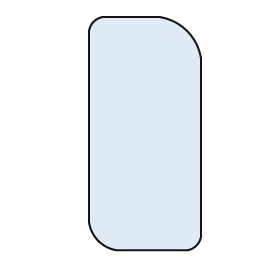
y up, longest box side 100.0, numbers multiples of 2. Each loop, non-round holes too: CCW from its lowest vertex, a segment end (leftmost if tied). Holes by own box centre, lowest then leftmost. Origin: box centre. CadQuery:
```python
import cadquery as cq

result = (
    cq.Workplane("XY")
    .moveTo(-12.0, -50.0)
    .lineTo(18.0, -50.0)
    .threePointArc((22.0, -48.0), (24.0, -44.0))
    .lineTo(24.0, 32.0)
    .threePointArc((18.0, 44.0), (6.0, 50.0))
    .lineTo(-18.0, 50.0)
    .threePointArc((-22.0, 48.0), (-24.0, 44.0))
    .lineTo(-24.0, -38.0)
    .threePointArc((-20.0, -46.0), (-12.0, -50.0))
    .close()
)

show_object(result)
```